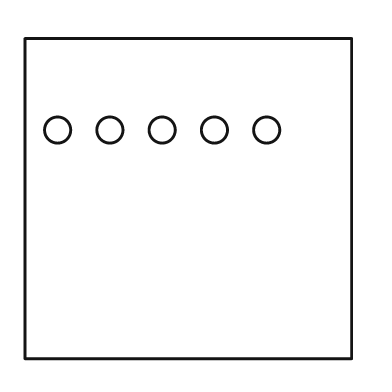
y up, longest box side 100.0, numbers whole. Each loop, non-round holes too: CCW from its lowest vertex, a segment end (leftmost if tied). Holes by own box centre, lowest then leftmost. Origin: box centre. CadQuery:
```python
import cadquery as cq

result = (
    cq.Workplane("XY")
    .moveTo(-50.0, -49.0)
    .lineTo(50.0, -49.0)
    .lineTo(50.0, 49.0)
    .lineTo(-50.0, 49.0)
    .close()
    .moveTo(-40.0, 21.0)
    .circle(4.0)
    .moveTo(-24.0, 21.0)
    .circle(4.0)
    .moveTo(-8.0, 21.0)
    .circle(4.0)
    .moveTo(8.0, 21.0)
    .circle(4.0)
    .moveTo(24.0, 21.0)
    .circle(4.0)
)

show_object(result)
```